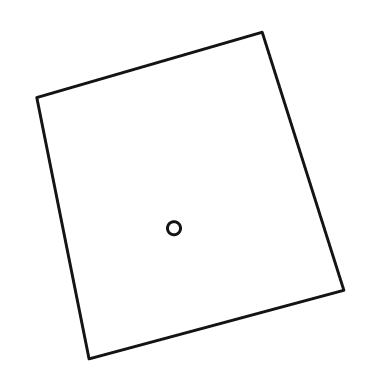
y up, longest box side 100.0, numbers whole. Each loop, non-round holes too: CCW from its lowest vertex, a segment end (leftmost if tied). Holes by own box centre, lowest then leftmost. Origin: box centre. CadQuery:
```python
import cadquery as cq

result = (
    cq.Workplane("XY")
    .moveTo(-31.0, -50.0)
    .lineTo(47.0, -29.0)
    .lineTo(22.0, 50.0)
    .lineTo(-47.0, 30.0)
    .close()
    .moveTo(-5.0, -10.0)
    .circle(2.0)
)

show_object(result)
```